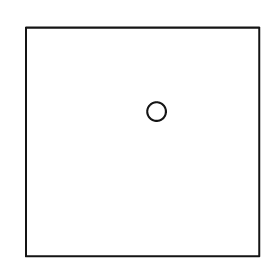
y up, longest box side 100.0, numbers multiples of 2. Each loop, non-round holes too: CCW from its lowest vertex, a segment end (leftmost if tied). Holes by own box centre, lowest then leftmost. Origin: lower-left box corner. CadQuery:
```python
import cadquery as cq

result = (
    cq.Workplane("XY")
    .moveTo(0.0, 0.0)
    .lineTo(100.0, 0.0)
    .lineTo(100.0, 98.0)
    .lineTo(0.0, 98.0)
    .close()
    .moveTo(56.0, 62.0)
    .circle(4.0)
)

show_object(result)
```